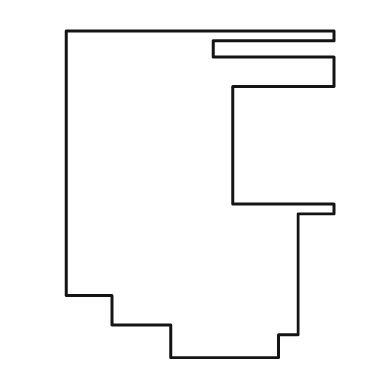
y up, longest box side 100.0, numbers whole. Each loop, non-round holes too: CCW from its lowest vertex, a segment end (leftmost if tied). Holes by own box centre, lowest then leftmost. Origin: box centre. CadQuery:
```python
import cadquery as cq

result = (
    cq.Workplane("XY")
    .moveTo(-9.0, -50.0)
    .lineTo(24.0, -50.0)
    .lineTo(24.0, -43.0)
    .lineTo(30.0, -43.0)
    .lineTo(30.0, -6.0)
    .lineTo(41.0, -6.0)
    .lineTo(41.0, -3.0)
    .lineTo(10.0, -3.0)
    .lineTo(10.0, 33.0)
    .lineTo(41.0, 33.0)
    .lineTo(41.0, 42.0)
    .lineTo(4.0, 42.0)
    .lineTo(4.0, 47.0)
    .lineTo(41.0, 47.0)
    .lineTo(41.0, 50.0)
    .lineTo(-41.0, 50.0)
    .lineTo(-41.0, -31.0)
    .lineTo(-27.0, -31.0)
    .lineTo(-27.0, -40.0)
    .lineTo(-9.0, -40.0)
    .close()
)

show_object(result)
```